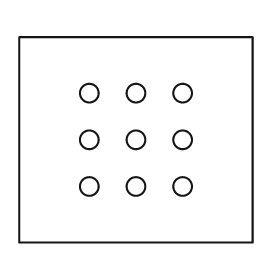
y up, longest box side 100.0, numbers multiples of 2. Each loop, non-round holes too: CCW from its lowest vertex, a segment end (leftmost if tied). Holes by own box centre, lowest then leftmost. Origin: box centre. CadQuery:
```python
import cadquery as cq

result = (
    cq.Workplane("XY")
    .moveTo(-50.0, -44.0)
    .lineTo(50.0, -44.0)
    .lineTo(50.0, 44.0)
    .lineTo(-50.0, 44.0)
    .close()
    .moveTo(-20.0, -20.0)
    .circle(4.0)
    .moveTo(0.0, -20.0)
    .circle(4.0)
    .moveTo(20.0, -20.0)
    .circle(4.0)
    .moveTo(-20.0, 0.0)
    .circle(4.0)
    .moveTo(0.0, 0.0)
    .circle(4.0)
    .moveTo(20.0, 0.0)
    .circle(4.0)
    .moveTo(-20.0, 20.0)
    .circle(4.0)
    .moveTo(0.0, 20.0)
    .circle(4.0)
    .moveTo(20.0, 20.0)
    .circle(4.0)
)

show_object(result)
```